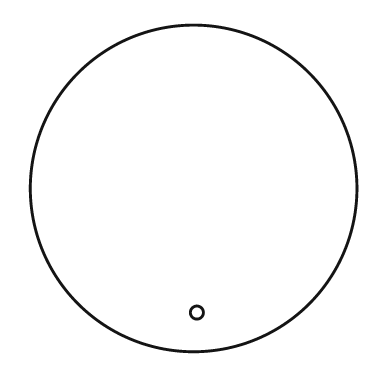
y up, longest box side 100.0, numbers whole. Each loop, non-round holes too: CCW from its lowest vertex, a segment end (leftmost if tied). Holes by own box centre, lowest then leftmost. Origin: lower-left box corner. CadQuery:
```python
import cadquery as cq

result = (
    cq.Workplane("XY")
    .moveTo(50.0, 50.0)
    .circle(50.0)
    .moveTo(51.0, 12.0)
    .circle(2.0)
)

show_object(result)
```